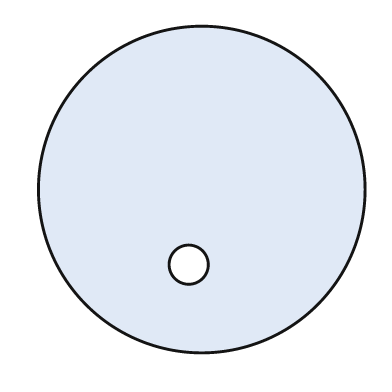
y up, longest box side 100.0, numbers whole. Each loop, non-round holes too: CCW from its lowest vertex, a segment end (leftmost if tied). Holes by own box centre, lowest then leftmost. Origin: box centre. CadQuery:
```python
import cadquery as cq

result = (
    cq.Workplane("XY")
    .moveTo(0.0, 0.0)
    .circle(50.0)
    .moveTo(-4.0, -23.0)
    .circle(6.0)
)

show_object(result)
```